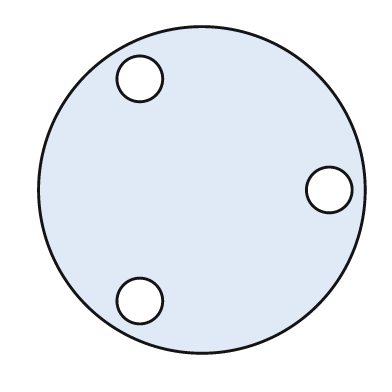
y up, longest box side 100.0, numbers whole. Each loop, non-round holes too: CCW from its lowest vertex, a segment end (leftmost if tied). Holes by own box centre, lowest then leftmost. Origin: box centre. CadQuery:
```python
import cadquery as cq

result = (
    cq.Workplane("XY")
    .moveTo(0.0, 0.0)
    .circle(50.0)
    .moveTo(-19.0, -34.0)
    .circle(7.0)
    .moveTo(39.0, 0.0)
    .circle(7.0)
    .moveTo(-19.0, 34.0)
    .circle(7.0)
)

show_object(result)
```